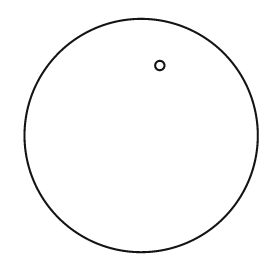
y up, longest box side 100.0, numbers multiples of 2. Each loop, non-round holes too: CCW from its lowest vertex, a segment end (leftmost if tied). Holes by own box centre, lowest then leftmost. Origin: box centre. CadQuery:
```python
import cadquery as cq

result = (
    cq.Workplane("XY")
    .moveTo(0.0, 0.0)
    .circle(50.0)
    .moveTo(8.0, 30.0)
    .circle(2.0)
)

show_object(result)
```